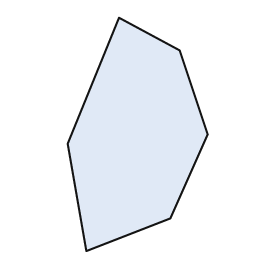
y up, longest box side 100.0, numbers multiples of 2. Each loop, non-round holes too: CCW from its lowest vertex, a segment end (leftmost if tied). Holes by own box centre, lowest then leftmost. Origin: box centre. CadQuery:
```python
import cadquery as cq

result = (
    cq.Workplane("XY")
    .moveTo(-22.0, -50.0)
    .lineTo(14.0, -36.0)
    .lineTo(30.0, 0.0)
    .lineTo(18.0, 36.0)
    .lineTo(-8.0, 50.0)
    .lineTo(-30.0, -4.0)
    .close()
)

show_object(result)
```